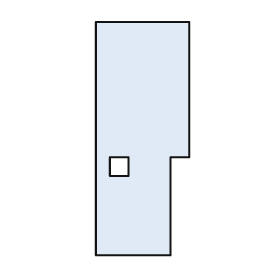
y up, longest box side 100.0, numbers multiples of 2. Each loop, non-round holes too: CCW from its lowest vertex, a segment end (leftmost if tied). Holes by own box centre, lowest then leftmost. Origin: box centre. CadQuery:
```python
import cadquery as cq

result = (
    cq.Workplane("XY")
    .moveTo(-20.0, -50.0)
    .lineTo(12.0, -50.0)
    .lineTo(12.0, -8.0)
    .lineTo(20.0, -8.0)
    .lineTo(20.0, 50.0)
    .lineTo(-20.0, 50.0)
    .close()
    .moveTo(-14.0, -16.0)
    .lineTo(-6.0, -16.0)
    .lineTo(-6.0, -8.0)
    .lineTo(-14.0, -8.0)
    .close()
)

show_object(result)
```